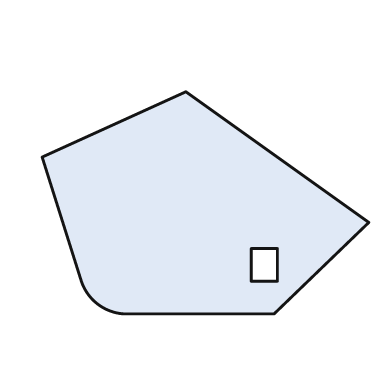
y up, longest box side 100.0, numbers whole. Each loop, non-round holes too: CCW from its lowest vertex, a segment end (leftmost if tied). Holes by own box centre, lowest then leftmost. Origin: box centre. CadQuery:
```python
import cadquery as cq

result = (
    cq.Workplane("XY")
    .moveTo(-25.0, -34.0)
    .lineTo(21.0, -34.0)
    .lineTo(50.0, -6.0)
    .lineTo(-6.0, 34.0)
    .lineTo(-50.0, 14.0)
    .lineTo(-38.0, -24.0)
    .threePointArc((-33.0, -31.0), (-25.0, -34.0))
    .close()
    .moveTo(14.0, -24.0)
    .lineTo(22.0, -24.0)
    .lineTo(22.0, -14.0)
    .lineTo(14.0, -14.0)
    .close()
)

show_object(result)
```